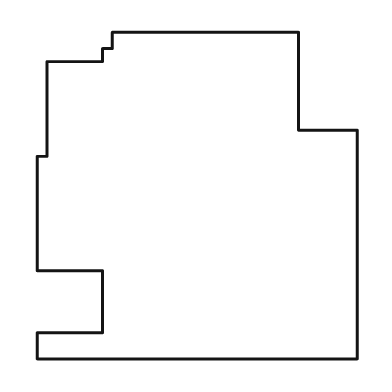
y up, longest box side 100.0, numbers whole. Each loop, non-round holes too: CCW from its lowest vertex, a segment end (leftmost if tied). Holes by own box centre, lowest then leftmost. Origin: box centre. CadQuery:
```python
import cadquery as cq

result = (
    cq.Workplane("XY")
    .moveTo(-49.0, -50.0)
    .lineTo(49.0, -50.0)
    .lineTo(49.0, 20.0)
    .lineTo(31.0, 20.0)
    .lineTo(31.0, 50.0)
    .lineTo(-26.0, 50.0)
    .lineTo(-26.0, 45.0)
    .lineTo(-29.0, 45.0)
    .lineTo(-29.0, 41.0)
    .lineTo(-46.0, 41.0)
    .lineTo(-46.0, 12.0)
    .lineTo(-49.0, 12.0)
    .lineTo(-49.0, -23.0)
    .lineTo(-29.0, -23.0)
    .lineTo(-29.0, -42.0)
    .lineTo(-49.0, -42.0)
    .close()
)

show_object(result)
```